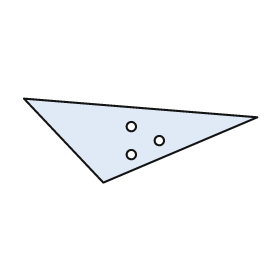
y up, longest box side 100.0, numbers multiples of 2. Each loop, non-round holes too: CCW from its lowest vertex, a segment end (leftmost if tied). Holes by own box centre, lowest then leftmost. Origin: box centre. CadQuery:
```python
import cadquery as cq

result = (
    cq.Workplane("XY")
    .moveTo(-16.0, -18.0)
    .lineTo(50.0, 10.0)
    .lineTo(-50.0, 18.0)
    .close()
    .moveTo(-4.0, -6.0)
    .circle(2.0)
    .moveTo(8.0, 0.0)
    .circle(2.0)
    .moveTo(-4.0, 6.0)
    .circle(2.0)
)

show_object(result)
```